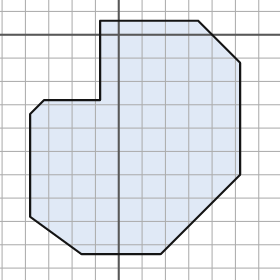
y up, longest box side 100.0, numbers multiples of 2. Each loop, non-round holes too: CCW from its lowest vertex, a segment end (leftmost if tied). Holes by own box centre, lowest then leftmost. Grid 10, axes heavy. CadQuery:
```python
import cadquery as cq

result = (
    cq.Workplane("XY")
    .moveTo(-16.0, -94.0)
    .lineTo(18.0, -94.0)
    .lineTo(52.0, -60.0)
    .lineTo(52.0, -12.0)
    .lineTo(34.0, 6.0)
    .lineTo(-8.0, 6.0)
    .lineTo(-8.0, -28.0)
    .lineTo(-32.0, -28.0)
    .lineTo(-38.0, -34.0)
    .lineTo(-38.0, -78.0)
    .close()
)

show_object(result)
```